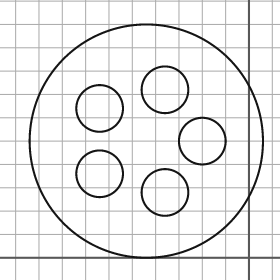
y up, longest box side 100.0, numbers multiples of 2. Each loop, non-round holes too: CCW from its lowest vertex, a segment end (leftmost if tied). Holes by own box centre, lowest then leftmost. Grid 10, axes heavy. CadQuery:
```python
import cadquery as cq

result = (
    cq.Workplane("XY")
    .moveTo(-44.0, 50.0)
    .circle(50.0)
    .moveTo(-36.0, 28.0)
    .circle(10.0)
    .moveTo(-64.0, 36.0)
    .circle(10.0)
    .moveTo(-20.0, 50.0)
    .circle(10.0)
    .moveTo(-64.0, 64.0)
    .circle(10.0)
    .moveTo(-36.0, 72.0)
    .circle(10.0)
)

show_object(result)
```